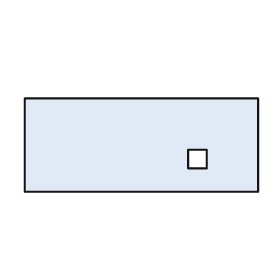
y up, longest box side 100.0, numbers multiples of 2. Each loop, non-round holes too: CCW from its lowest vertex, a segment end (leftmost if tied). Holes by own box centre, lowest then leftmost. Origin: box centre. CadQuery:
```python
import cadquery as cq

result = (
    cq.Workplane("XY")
    .moveTo(-50.0, -20.0)
    .lineTo(50.0, -20.0)
    .lineTo(50.0, 20.0)
    .lineTo(-50.0, 20.0)
    .close()
    .moveTo(20.0, -10.0)
    .lineTo(28.0, -10.0)
    .lineTo(28.0, -2.0)
    .lineTo(20.0, -2.0)
    .close()
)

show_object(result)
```